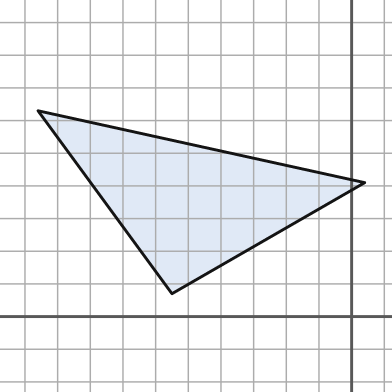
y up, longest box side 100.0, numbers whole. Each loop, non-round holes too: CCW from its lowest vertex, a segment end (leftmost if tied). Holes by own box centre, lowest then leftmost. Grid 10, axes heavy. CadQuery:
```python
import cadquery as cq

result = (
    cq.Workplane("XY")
    .moveTo(-55.0, 7.0)
    .lineTo(4.0, 41.0)
    .lineTo(-96.0, 63.0)
    .close()
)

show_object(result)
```